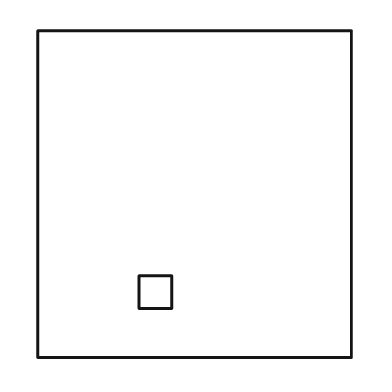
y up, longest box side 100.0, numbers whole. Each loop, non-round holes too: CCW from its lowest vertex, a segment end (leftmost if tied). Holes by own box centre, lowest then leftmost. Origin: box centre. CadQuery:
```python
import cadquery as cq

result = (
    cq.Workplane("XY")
    .moveTo(-48.0, -50.0)
    .lineTo(48.0, -50.0)
    .lineTo(48.0, 50.0)
    .lineTo(-48.0, 50.0)
    .close()
    .moveTo(-17.0, -35.0)
    .lineTo(-7.0, -35.0)
    .lineTo(-7.0, -25.0)
    .lineTo(-17.0, -25.0)
    .close()
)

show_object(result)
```